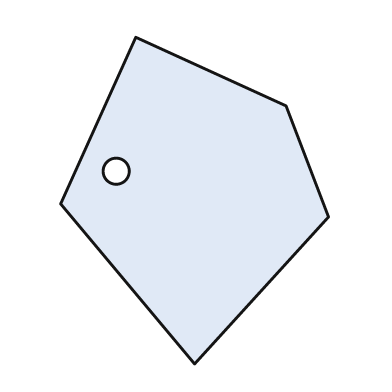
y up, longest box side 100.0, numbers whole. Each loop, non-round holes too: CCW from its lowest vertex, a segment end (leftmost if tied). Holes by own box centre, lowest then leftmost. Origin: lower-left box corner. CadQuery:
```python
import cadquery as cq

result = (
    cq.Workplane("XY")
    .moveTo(41.0, 0.0)
    .lineTo(82.0, 45.0)
    .lineTo(69.0, 79.0)
    .lineTo(23.0, 100.0)
    .lineTo(0.0, 49.0)
    .close()
    .moveTo(17.0, 59.0)
    .circle(4.0)
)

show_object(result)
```